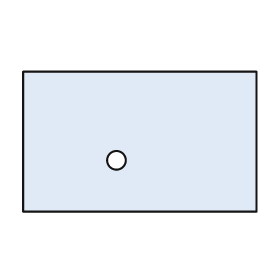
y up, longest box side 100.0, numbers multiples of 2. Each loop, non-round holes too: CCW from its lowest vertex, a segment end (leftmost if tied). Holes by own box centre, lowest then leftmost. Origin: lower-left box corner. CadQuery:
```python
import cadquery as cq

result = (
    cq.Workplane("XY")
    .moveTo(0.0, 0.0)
    .lineTo(100.0, 0.0)
    .lineTo(100.0, 60.0)
    .lineTo(0.0, 60.0)
    .close()
    .moveTo(40.0, 22.0)
    .circle(4.0)
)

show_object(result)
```